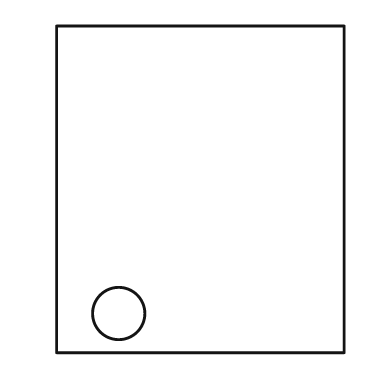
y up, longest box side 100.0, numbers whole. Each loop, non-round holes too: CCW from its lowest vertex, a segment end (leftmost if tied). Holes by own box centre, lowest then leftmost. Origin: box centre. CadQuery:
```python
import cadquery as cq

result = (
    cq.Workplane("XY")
    .moveTo(-44.0, -50.0)
    .lineTo(44.0, -50.0)
    .lineTo(44.0, 50.0)
    .lineTo(-44.0, 50.0)
    .close()
    .moveTo(-25.0, -38.0)
    .circle(8.0)
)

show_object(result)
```